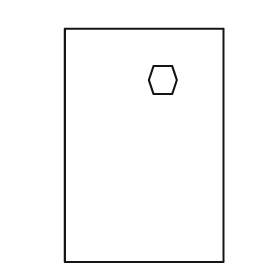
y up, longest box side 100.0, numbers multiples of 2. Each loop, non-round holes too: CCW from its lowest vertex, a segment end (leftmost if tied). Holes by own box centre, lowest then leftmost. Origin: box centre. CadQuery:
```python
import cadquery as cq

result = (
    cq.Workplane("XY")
    .moveTo(-34.0, -50.0)
    .lineTo(34.0, -50.0)
    .lineTo(34.0, 50.0)
    .lineTo(-34.0, 50.0)
    .close()
    .moveTo(4.0, 22.0)
    .lineTo(12.0, 22.0)
    .lineTo(14.0, 28.0)
    .lineTo(12.0, 34.0)
    .lineTo(4.0, 34.0)
    .lineTo(2.0, 28.0)
    .close()
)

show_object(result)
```